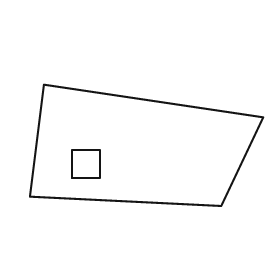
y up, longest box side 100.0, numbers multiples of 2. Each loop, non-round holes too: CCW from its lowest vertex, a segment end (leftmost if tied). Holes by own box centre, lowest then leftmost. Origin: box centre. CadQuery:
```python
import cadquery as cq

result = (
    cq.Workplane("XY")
    .moveTo(32.0, -26.0)
    .lineTo(50.0, 12.0)
    .lineTo(-44.0, 26.0)
    .lineTo(-50.0, -22.0)
    .close()
    .moveTo(-32.0, -14.0)
    .lineTo(-20.0, -14.0)
    .lineTo(-20.0, -2.0)
    .lineTo(-32.0, -2.0)
    .close()
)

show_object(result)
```